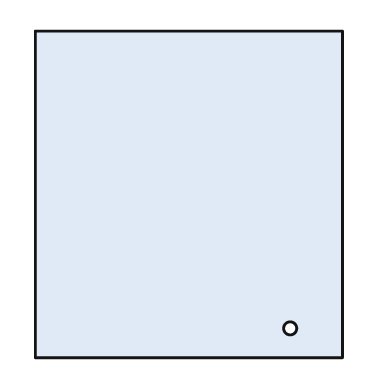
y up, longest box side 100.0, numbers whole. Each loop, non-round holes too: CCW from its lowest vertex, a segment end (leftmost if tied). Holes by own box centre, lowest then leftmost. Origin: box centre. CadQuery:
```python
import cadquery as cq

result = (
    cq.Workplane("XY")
    .moveTo(-47.0, -50.0)
    .lineTo(47.0, -50.0)
    .lineTo(47.0, 50.0)
    .lineTo(-47.0, 50.0)
    .close()
    .moveTo(31.0, -41.0)
    .circle(2.0)
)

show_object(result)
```